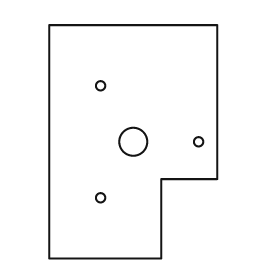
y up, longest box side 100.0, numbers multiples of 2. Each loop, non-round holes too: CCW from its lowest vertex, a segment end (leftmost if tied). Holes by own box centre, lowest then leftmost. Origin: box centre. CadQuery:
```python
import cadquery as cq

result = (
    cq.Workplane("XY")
    .moveTo(-36.0, -50.0)
    .lineTo(12.0, -50.0)
    .lineTo(12.0, -16.0)
    .lineTo(36.0, -16.0)
    .lineTo(36.0, 50.0)
    .lineTo(-36.0, 50.0)
    .close()
    .moveTo(-14.0, -24.0)
    .circle(2.0)
    .moveTo(0.0, 0.0)
    .circle(6.0)
    .moveTo(28.0, 0.0)
    .circle(2.0)
    .moveTo(-14.0, 24.0)
    .circle(2.0)
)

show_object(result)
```